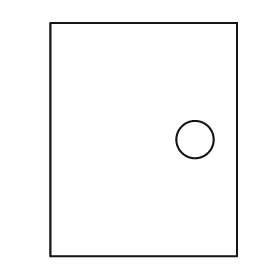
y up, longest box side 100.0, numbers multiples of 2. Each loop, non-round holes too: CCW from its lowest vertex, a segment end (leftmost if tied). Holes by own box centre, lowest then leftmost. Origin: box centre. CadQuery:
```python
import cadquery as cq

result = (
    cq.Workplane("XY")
    .moveTo(-40.0, -50.0)
    .lineTo(40.0, -50.0)
    .lineTo(40.0, 50.0)
    .lineTo(-40.0, 50.0)
    .close()
    .moveTo(22.0, 0.0)
    .circle(8.0)
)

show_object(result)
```